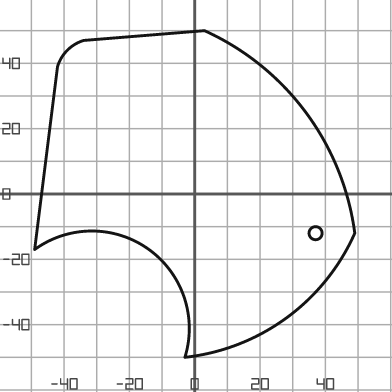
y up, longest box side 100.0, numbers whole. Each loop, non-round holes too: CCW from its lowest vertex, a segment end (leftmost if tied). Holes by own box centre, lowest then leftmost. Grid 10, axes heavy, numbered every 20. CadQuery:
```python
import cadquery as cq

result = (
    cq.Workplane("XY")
    .moveTo(-3.0, -50.0)
    .threePointArc((28.0, -38.0), (49.0, -12.0))
    .threePointArc((34.0, 25.0), (3.0, 50.0))
    .lineTo(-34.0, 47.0)
    .threePointArc((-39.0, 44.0), (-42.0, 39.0))
    .lineTo(-49.0, -17.0)
    .threePointArc((-14.0, -17.0), (-3.0, -50.0))
    .close()
    .moveTo(37.0, -12.0)
    .circle(2.0)
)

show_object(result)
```